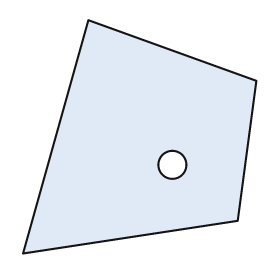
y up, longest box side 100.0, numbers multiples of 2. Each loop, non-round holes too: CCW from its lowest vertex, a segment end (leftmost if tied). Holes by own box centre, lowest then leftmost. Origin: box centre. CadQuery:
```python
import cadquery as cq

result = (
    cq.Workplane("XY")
    .moveTo(-50.0, -50.0)
    .lineTo(42.0, -36.0)
    .lineTo(50.0, 24.0)
    .lineTo(-22.0, 50.0)
    .close()
    .moveTo(14.0, -12.0)
    .circle(6.0)
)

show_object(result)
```